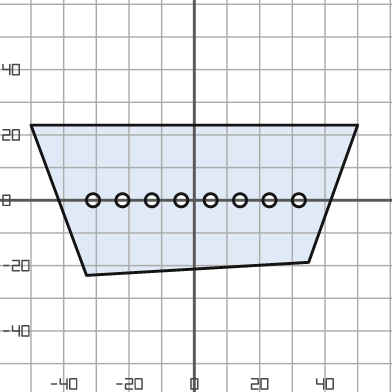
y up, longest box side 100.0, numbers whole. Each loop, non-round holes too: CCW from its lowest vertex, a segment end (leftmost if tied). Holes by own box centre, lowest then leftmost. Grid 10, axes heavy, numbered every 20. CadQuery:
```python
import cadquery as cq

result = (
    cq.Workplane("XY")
    .moveTo(-33.0, -23.0)
    .lineTo(35.0, -19.0)
    .lineTo(50.0, 23.0)
    .lineTo(-50.0, 23.0)
    .close()
    .moveTo(-31.0, 0.0)
    .circle(2.0)
    .moveTo(-22.0, 0.0)
    .circle(2.0)
    .moveTo(-13.0, 0.0)
    .circle(2.0)
    .moveTo(-4.0, 0.0)
    .circle(2.0)
    .moveTo(5.0, 0.0)
    .circle(2.0)
    .moveTo(14.0, 0.0)
    .circle(2.0)
    .moveTo(23.0, 0.0)
    .circle(2.0)
    .moveTo(32.0, 0.0)
    .circle(2.0)
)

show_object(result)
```